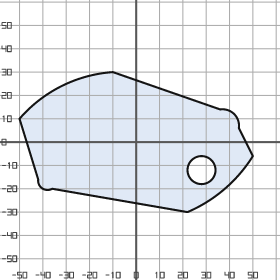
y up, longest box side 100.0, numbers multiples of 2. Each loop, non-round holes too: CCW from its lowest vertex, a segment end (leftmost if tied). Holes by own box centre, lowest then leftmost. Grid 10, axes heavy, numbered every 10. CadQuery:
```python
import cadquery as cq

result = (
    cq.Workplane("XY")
    .moveTo(22.0, -30.0)
    .threePointArc((38.0, -20.0), (50.0, -6.0))
    .lineTo(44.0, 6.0)
    .threePointArc((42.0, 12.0), (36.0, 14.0))
    .lineTo(-10.0, 30.0)
    .threePointArc((-32.0, 24.0), (-50.0, 10.0))
    .lineTo(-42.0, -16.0)
    .threePointArc((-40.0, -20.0), (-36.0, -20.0))
    .close()
    .moveTo(28.0, -12.0)
    .circle(6.0)
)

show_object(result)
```